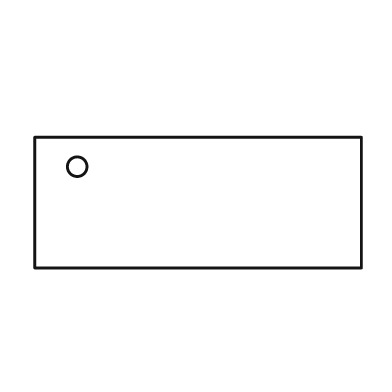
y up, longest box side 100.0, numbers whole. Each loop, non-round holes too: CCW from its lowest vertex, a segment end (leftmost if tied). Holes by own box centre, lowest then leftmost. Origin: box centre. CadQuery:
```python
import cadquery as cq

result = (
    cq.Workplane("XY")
    .moveTo(-50.0, -20.0)
    .lineTo(50.0, -20.0)
    .lineTo(50.0, 20.0)
    .lineTo(-50.0, 20.0)
    .close()
    .moveTo(-37.0, 11.0)
    .circle(3.0)
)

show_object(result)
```